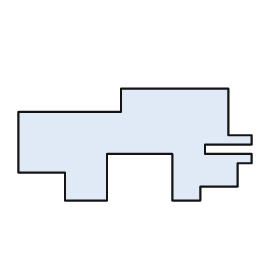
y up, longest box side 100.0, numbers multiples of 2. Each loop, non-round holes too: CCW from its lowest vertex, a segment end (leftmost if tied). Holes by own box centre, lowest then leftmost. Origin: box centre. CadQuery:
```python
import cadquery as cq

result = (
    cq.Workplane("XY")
    .moveTo(-30.0, -24.0)
    .lineTo(-12.0, -24.0)
    .lineTo(-12.0, -4.0)
    .lineTo(16.0, -4.0)
    .lineTo(16.0, -24.0)
    .lineTo(28.0, -24.0)
    .lineTo(28.0, -18.0)
    .lineTo(44.0, -18.0)
    .lineTo(44.0, -8.0)
    .lineTo(50.0, -8.0)
    .lineTo(50.0, -4.0)
    .lineTo(30.0, -4.0)
    .lineTo(30.0, 0.0)
    .lineTo(50.0, 0.0)
    .lineTo(50.0, 4.0)
    .lineTo(40.0, 4.0)
    .lineTo(40.0, 24.0)
    .lineTo(-6.0, 24.0)
    .lineTo(-6.0, 14.0)
    .lineTo(-50.0, 14.0)
    .lineTo(-50.0, -12.0)
    .lineTo(-30.0, -12.0)
    .close()
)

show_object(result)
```